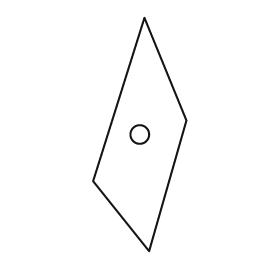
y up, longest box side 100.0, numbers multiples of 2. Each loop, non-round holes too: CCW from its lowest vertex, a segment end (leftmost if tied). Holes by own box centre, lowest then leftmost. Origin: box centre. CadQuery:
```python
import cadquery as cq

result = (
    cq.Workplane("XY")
    .moveTo(4.0, -50.0)
    .lineTo(20.0, 6.0)
    .lineTo(2.0, 50.0)
    .lineTo(-20.0, -20.0)
    .close()
    .moveTo(0.0, 0.0)
    .circle(4.0)
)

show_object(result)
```